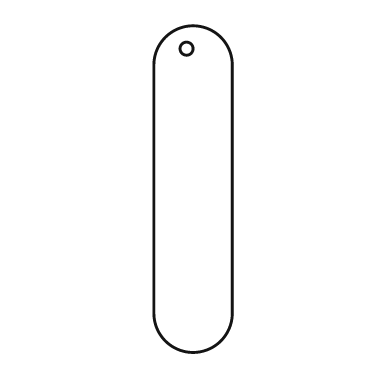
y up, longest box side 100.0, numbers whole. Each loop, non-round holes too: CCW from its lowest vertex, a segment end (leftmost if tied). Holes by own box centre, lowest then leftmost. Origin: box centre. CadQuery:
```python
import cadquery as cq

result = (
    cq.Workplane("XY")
    .moveTo(-12.0, -38.0)
    .threePointArc((0.0, -50.0), (12.0, -38.0))
    .lineTo(12.0, 38.0)
    .threePointArc((0.0, 50.0), (-12.0, 38.0))
    .close()
    .moveTo(-2.0, 43.0)
    .circle(2.0)
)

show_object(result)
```